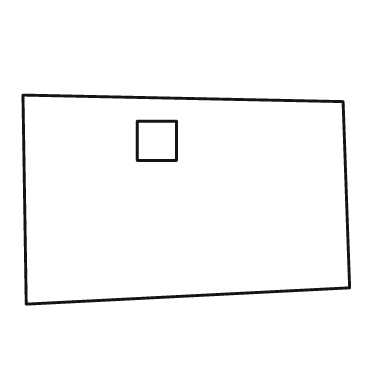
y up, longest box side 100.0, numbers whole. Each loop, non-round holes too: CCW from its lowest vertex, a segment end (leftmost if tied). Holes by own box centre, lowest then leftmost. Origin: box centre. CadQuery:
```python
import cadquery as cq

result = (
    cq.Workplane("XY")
    .moveTo(-49.0, -32.0)
    .lineTo(50.0, -27.0)
    .lineTo(48.0, 30.0)
    .lineTo(-50.0, 32.0)
    .close()
    .moveTo(-15.0, 12.0)
    .lineTo(-3.0, 12.0)
    .lineTo(-3.0, 24.0)
    .lineTo(-15.0, 24.0)
    .close()
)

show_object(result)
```